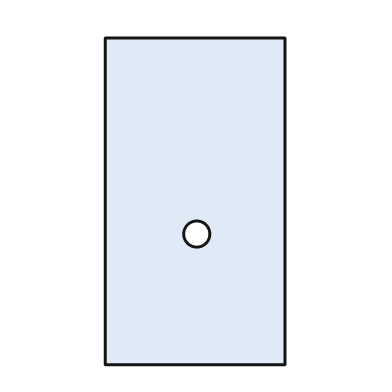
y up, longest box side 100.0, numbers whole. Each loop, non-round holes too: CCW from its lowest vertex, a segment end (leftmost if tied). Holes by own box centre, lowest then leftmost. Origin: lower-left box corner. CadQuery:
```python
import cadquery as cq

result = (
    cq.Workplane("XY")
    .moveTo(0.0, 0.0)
    .lineTo(55.0, 0.0)
    .lineTo(55.0, 100.0)
    .lineTo(0.0, 100.0)
    .close()
    .moveTo(28.0, 40.0)
    .circle(4.0)
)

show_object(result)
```